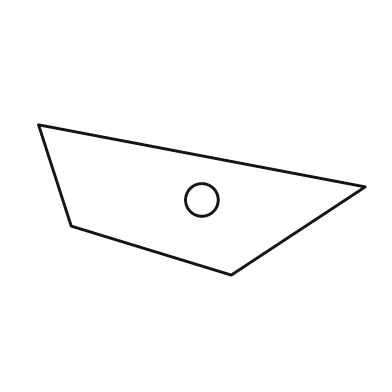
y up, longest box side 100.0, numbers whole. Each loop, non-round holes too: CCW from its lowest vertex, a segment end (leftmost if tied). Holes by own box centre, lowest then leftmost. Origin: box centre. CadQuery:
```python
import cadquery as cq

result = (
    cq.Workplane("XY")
    .moveTo(9.0, -23.0)
    .lineTo(50.0, 4.0)
    .lineTo(-50.0, 23.0)
    .lineTo(-40.0, -8.0)
    .close()
    .moveTo(0.0, 0.0)
    .circle(5.0)
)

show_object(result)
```